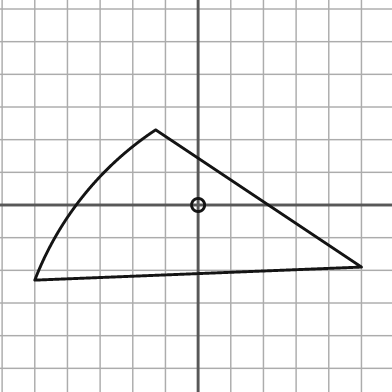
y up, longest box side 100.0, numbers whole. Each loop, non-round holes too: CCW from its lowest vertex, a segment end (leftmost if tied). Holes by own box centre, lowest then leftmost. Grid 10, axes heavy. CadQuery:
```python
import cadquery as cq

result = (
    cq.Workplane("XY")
    .moveTo(-50.0, -23.0)
    .lineTo(50.0, -19.0)
    .lineTo(-13.0, 23.0)
    .threePointArc((-35.0, 3.0), (-50.0, -23.0))
    .close()
    .moveTo(0.0, 0.0)
    .circle(2.0)
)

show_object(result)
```